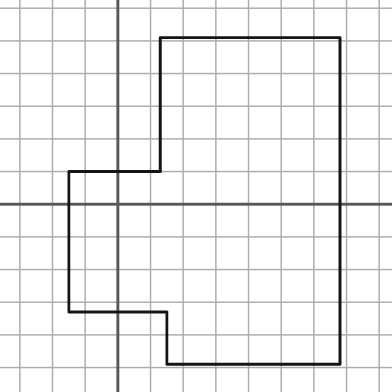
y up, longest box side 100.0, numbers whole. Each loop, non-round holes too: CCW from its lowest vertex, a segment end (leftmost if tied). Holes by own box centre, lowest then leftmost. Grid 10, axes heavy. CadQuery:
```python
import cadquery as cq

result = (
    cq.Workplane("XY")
    .moveTo(15.0, -49.0)
    .lineTo(68.0, -49.0)
    .lineTo(68.0, 51.0)
    .lineTo(13.0, 51.0)
    .lineTo(13.0, 10.0)
    .lineTo(-15.0, 10.0)
    .lineTo(-15.0, -33.0)
    .lineTo(15.0, -33.0)
    .close()
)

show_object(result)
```